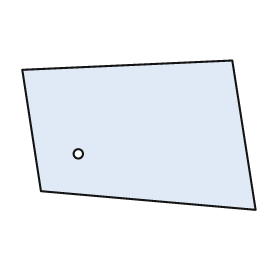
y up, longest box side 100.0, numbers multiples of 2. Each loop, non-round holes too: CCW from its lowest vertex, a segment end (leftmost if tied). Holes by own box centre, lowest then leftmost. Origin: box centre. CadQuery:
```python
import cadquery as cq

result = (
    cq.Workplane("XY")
    .moveTo(50.0, -32.0)
    .lineTo(40.0, 32.0)
    .lineTo(-50.0, 28.0)
    .lineTo(-42.0, -24.0)
    .close()
    .moveTo(-26.0, -8.0)
    .circle(2.0)
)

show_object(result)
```